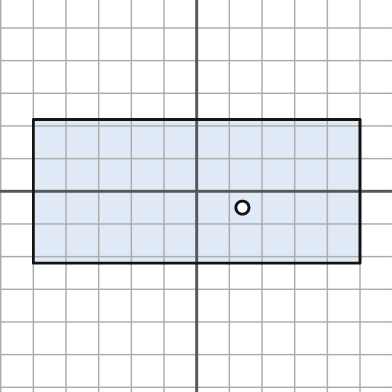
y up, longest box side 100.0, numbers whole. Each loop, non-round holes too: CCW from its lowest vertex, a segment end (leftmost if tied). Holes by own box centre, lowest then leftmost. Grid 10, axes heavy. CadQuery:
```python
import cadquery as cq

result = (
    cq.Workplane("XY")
    .moveTo(-50.0, -22.0)
    .lineTo(50.0, -22.0)
    .lineTo(50.0, 22.0)
    .lineTo(-50.0, 22.0)
    .close()
    .moveTo(14.0, -5.0)
    .circle(2.0)
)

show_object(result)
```